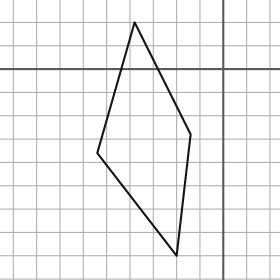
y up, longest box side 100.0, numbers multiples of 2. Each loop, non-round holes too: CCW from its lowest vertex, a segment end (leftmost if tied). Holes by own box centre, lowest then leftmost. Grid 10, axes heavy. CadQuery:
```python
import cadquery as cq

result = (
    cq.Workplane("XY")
    .moveTo(-20.0, -80.0)
    .lineTo(-14.0, -28.0)
    .lineTo(-38.0, 20.0)
    .lineTo(-54.0, -36.0)
    .close()
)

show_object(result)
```